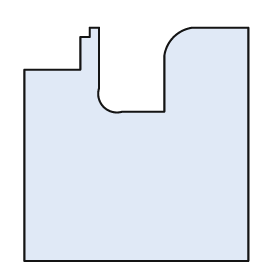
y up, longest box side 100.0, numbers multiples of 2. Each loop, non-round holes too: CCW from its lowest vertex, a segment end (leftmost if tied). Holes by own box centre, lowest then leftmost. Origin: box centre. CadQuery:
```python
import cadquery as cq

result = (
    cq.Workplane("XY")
    .moveTo(-48.0, -50.0)
    .lineTo(48.0, -50.0)
    .lineTo(48.0, 50.0)
    .lineTo(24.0, 50.0)
    .threePointArc((16.0, 46.0), (12.0, 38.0))
    .lineTo(12.0, 14.0)
    .lineTo(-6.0, 14.0)
    .threePointArc((-14.0, 16.0), (-16.0, 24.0))
    .lineTo(-16.0, 50.0)
    .lineTo(-20.0, 50.0)
    .lineTo(-20.0, 46.0)
    .lineTo(-24.0, 46.0)
    .lineTo(-24.0, 32.0)
    .lineTo(-48.0, 32.0)
    .close()
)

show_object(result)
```